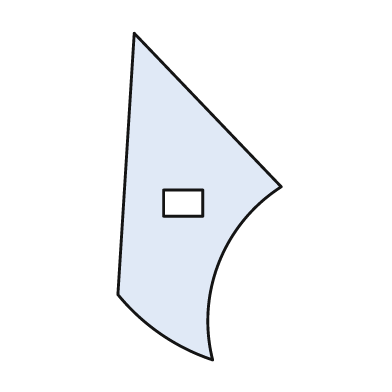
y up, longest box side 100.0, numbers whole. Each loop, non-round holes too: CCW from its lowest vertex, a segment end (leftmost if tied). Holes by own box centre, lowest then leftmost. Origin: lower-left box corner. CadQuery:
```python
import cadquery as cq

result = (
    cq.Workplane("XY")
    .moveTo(29.0, 0.0)
    .threePointArc((31.0, 30.0), (50.0, 53.0))
    .lineTo(5.0, 100.0)
    .lineTo(0.0, 20.0)
    .threePointArc((13.0, 8.0), (29.0, 0.0))
    .close()
    .moveTo(14.0, 44.0)
    .lineTo(26.0, 44.0)
    .lineTo(26.0, 52.0)
    .lineTo(14.0, 52.0)
    .close()
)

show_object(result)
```